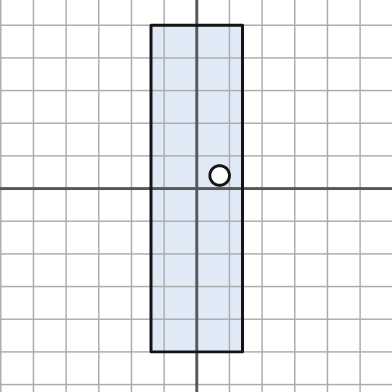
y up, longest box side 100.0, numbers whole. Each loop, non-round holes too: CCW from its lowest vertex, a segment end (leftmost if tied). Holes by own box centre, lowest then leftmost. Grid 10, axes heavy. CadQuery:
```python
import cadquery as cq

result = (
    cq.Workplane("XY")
    .moveTo(-14.0, -50.0)
    .lineTo(14.0, -50.0)
    .lineTo(14.0, 50.0)
    .lineTo(-14.0, 50.0)
    .close()
    .moveTo(7.0, 4.0)
    .circle(3.0)
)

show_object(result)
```